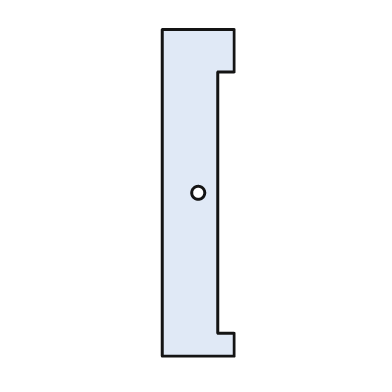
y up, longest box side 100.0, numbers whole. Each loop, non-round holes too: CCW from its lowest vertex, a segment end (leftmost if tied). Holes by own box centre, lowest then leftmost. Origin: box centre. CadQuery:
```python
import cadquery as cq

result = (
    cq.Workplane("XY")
    .moveTo(-11.0, -50.0)
    .lineTo(11.0, -50.0)
    .lineTo(11.0, -43.0)
    .lineTo(6.0, -43.0)
    .lineTo(6.0, 37.0)
    .lineTo(11.0, 37.0)
    .lineTo(11.0, 50.0)
    .lineTo(-11.0, 50.0)
    .close()
    .moveTo(0.0, 0.0)
    .circle(2.0)
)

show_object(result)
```